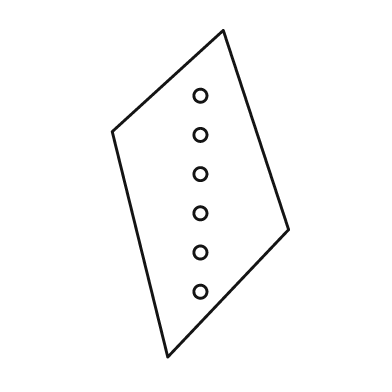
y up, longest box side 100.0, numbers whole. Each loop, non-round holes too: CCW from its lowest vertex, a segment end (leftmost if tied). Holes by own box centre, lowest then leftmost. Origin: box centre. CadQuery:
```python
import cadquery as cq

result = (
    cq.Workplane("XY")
    .moveTo(-10.0, -50.0)
    .lineTo(27.0, -11.0)
    .lineTo(7.0, 50.0)
    .lineTo(-27.0, 19.0)
    .close()
    .moveTo(0.0, -30.0)
    .circle(2.0)
    .moveTo(0.0, -18.0)
    .circle(2.0)
    .moveTo(0.0, -6.0)
    .circle(2.0)
    .moveTo(0.0, 6.0)
    .circle(2.0)
    .moveTo(0.0, 18.0)
    .circle(2.0)
    .moveTo(0.0, 30.0)
    .circle(2.0)
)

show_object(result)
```